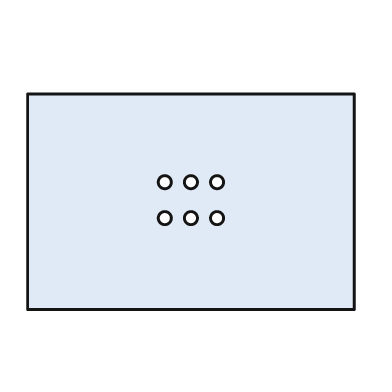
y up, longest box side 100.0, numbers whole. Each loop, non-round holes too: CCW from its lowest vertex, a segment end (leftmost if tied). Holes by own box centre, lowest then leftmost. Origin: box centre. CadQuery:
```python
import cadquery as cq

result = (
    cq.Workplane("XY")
    .moveTo(-50.0, -33.0)
    .lineTo(50.0, -33.0)
    .lineTo(50.0, 33.0)
    .lineTo(-50.0, 33.0)
    .close()
    .moveTo(-8.0, -5.0)
    .circle(2.0)
    .moveTo(0.0, -5.0)
    .circle(2.0)
    .moveTo(8.0, -5.0)
    .circle(2.0)
    .moveTo(-8.0, 6.0)
    .circle(2.0)
    .moveTo(0.0, 6.0)
    .circle(2.0)
    .moveTo(8.0, 6.0)
    .circle(2.0)
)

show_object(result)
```